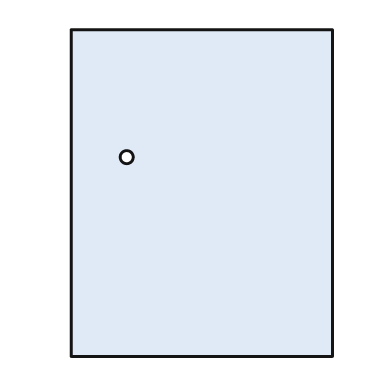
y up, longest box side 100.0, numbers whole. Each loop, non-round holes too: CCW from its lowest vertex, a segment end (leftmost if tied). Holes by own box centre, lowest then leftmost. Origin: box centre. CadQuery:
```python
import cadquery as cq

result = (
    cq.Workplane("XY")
    .moveTo(-40.0, -50.0)
    .lineTo(40.0, -50.0)
    .lineTo(40.0, 50.0)
    .lineTo(-40.0, 50.0)
    .close()
    .moveTo(-23.0, 11.0)
    .circle(2.0)
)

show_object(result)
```